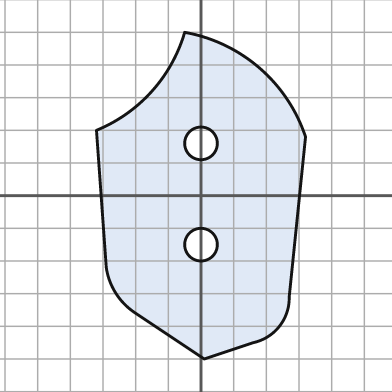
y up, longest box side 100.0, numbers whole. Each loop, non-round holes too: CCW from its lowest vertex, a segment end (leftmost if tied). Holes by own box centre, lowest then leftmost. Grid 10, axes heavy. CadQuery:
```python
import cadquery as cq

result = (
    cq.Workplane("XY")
    .moveTo(1.0, -50.0)
    .lineTo(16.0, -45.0)
    .threePointArc((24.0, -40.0), (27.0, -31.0))
    .lineTo(32.0, 18.0)
    .threePointArc((18.0, 39.0), (-5.0, 50.0))
    .threePointArc((-15.0, 32.0), (-32.0, 20.0))
    .lineTo(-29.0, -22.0)
    .threePointArc((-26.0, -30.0), (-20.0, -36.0))
    .close()
    .moveTo(0.0, -15.0)
    .circle(5.0)
    .moveTo(0.0, 16.0)
    .circle(5.0)
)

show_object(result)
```